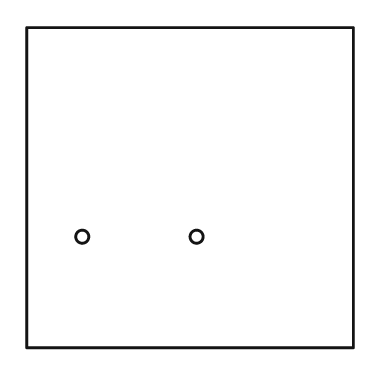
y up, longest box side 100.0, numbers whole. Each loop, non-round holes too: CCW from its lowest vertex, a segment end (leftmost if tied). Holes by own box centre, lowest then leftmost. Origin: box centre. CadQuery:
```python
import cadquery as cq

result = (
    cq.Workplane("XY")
    .moveTo(-50.0, -49.0)
    .lineTo(50.0, -49.0)
    .lineTo(50.0, 49.0)
    .lineTo(-50.0, 49.0)
    .close()
    .moveTo(-33.0, -15.0)
    .circle(2.0)
    .moveTo(2.0, -15.0)
    .circle(2.0)
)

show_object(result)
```